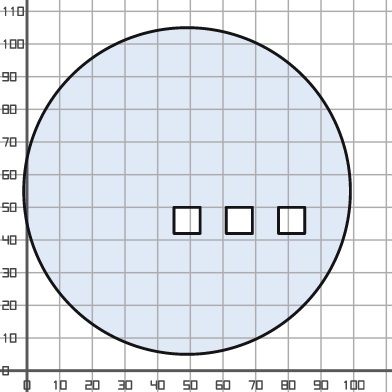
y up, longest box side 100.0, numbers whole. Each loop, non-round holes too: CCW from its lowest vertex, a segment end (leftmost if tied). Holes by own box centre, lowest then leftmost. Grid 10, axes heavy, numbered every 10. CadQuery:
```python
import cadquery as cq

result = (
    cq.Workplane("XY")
    .moveTo(49.0, 55.0)
    .circle(50.0)
    .moveTo(45.0, 42.0)
    .lineTo(53.0, 42.0)
    .lineTo(53.0, 50.0)
    .lineTo(45.0, 50.0)
    .close()
    .moveTo(61.0, 42.0)
    .lineTo(69.0, 42.0)
    .lineTo(69.0, 50.0)
    .lineTo(61.0, 50.0)
    .close()
    .moveTo(77.0, 42.0)
    .lineTo(85.0, 42.0)
    .lineTo(85.0, 50.0)
    .lineTo(77.0, 50.0)
    .close()
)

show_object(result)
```